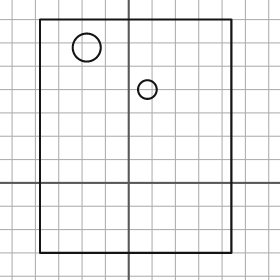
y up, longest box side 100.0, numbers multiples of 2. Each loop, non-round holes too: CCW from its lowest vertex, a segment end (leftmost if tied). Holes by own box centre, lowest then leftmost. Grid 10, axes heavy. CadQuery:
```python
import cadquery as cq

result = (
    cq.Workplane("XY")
    .moveTo(-38.0, -30.0)
    .lineTo(44.0, -30.0)
    .lineTo(44.0, 70.0)
    .lineTo(-38.0, 70.0)
    .close()
    .moveTo(8.0, 40.0)
    .circle(4.0)
    .moveTo(-18.0, 58.0)
    .circle(6.0)
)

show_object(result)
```